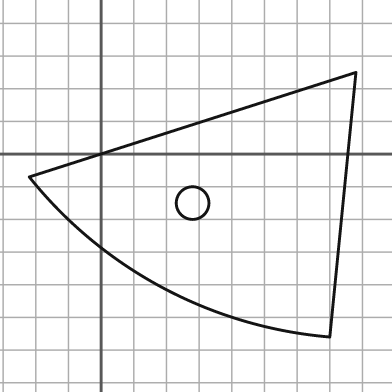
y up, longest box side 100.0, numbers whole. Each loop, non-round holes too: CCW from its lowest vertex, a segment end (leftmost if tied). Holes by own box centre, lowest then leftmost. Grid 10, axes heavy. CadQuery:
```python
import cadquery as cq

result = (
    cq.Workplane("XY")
    .moveTo(70.0, -56.0)
    .lineTo(78.0, 25.0)
    .lineTo(-22.0, -7.0)
    .threePointArc((19.0, -41.0), (70.0, -56.0))
    .close()
    .moveTo(28.0, -15.0)
    .circle(5.0)
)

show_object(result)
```